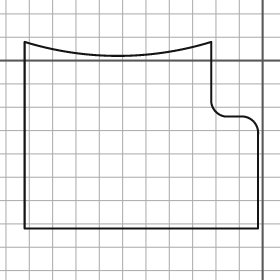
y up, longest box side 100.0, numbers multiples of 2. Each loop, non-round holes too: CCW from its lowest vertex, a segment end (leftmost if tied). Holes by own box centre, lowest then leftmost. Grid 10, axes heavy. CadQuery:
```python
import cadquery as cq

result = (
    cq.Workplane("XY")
    .moveTo(-102.0, -72.0)
    .lineTo(-2.0, -72.0)
    .lineTo(-2.0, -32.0)
    .threePointArc((-4.0, -26.0), (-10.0, -24.0))
    .lineTo(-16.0, -24.0)
    .threePointArc((-20.0, -22.0), (-22.0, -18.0))
    .lineTo(-22.0, 8.0)
    .threePointArc((-62.0, 2.0), (-102.0, 8.0))
    .close()
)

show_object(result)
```